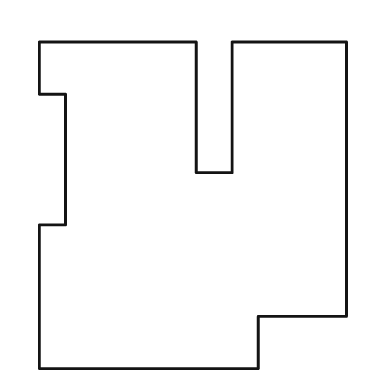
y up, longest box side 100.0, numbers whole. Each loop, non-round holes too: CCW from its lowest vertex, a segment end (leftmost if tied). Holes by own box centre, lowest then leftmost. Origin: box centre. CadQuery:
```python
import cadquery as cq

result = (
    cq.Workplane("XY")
    .moveTo(-47.0, -50.0)
    .lineTo(20.0, -50.0)
    .lineTo(20.0, -34.0)
    .lineTo(47.0, -34.0)
    .lineTo(47.0, 50.0)
    .lineTo(12.0, 50.0)
    .lineTo(12.0, 10.0)
    .lineTo(1.0, 10.0)
    .lineTo(1.0, 50.0)
    .lineTo(-47.0, 50.0)
    .lineTo(-47.0, 34.0)
    .lineTo(-39.0, 34.0)
    .lineTo(-39.0, -6.0)
    .lineTo(-47.0, -6.0)
    .close()
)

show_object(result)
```